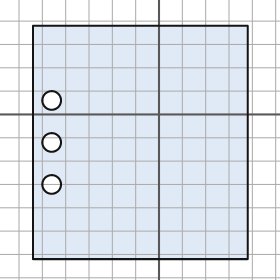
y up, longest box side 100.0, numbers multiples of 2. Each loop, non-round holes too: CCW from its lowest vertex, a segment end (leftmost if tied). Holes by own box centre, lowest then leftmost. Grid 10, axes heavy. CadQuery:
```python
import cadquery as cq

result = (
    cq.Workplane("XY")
    .moveTo(-54.0, -62.0)
    .lineTo(38.0, -62.0)
    .lineTo(38.0, 38.0)
    .lineTo(-54.0, 38.0)
    .close()
    .moveTo(-46.0, -30.0)
    .circle(4.0)
    .moveTo(-46.0, -12.0)
    .circle(4.0)
    .moveTo(-46.0, 6.0)
    .circle(4.0)
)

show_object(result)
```